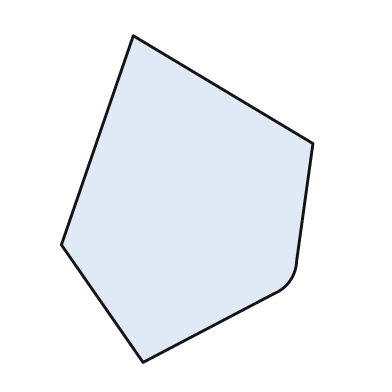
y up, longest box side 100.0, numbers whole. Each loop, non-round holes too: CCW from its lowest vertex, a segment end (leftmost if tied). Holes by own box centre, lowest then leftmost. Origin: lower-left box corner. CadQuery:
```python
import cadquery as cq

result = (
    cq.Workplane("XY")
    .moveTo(25.0, 0.0)
    .lineTo(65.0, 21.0)
    .threePointArc((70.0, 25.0), (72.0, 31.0))
    .lineTo(77.0, 67.0)
    .lineTo(22.0, 100.0)
    .lineTo(0.0, 36.0)
    .close()
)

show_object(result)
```